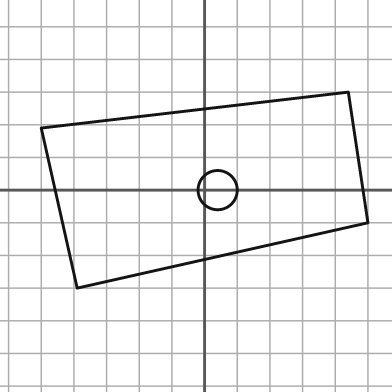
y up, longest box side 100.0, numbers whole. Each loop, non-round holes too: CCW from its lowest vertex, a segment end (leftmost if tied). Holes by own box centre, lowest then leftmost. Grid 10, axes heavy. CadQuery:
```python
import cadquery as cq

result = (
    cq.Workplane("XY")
    .moveTo(-39.0, -30.0)
    .lineTo(50.0, -10.0)
    .lineTo(44.0, 30.0)
    .lineTo(-50.0, 19.0)
    .close()
    .moveTo(4.0, 0.0)
    .circle(6.0)
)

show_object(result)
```